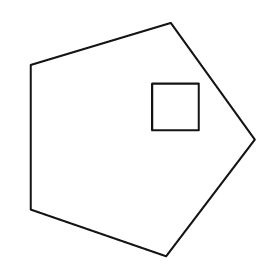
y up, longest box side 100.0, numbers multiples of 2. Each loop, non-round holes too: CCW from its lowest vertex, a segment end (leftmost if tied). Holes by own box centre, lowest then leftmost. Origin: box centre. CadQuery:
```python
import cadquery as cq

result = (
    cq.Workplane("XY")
    .moveTo(10.0, -50.0)
    .lineTo(48.0, 0.0)
    .lineTo(12.0, 50.0)
    .lineTo(-48.0, 32.0)
    .lineTo(-48.0, -30.0)
    .close()
    .moveTo(4.0, 4.0)
    .lineTo(24.0, 4.0)
    .lineTo(24.0, 24.0)
    .lineTo(4.0, 24.0)
    .close()
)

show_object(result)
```